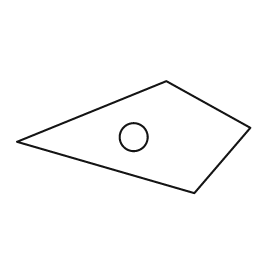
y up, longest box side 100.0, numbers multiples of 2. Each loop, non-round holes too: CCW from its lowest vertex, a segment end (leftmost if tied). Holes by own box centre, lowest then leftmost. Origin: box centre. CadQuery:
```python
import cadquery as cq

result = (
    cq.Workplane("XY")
    .moveTo(26.0, -24.0)
    .lineTo(50.0, 4.0)
    .lineTo(14.0, 24.0)
    .lineTo(-50.0, -2.0)
    .close()
    .moveTo(0.0, 0.0)
    .circle(6.0)
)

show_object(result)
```